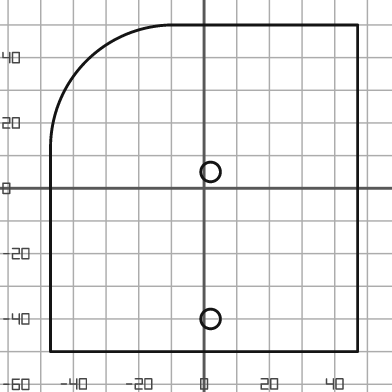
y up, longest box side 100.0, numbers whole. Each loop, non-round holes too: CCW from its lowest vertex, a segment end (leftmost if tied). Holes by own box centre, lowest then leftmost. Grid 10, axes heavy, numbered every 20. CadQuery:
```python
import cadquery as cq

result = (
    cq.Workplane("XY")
    .moveTo(-47.0, -50.0)
    .lineTo(47.0, -50.0)
    .lineTo(47.0, 50.0)
    .lineTo(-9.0, 50.0)
    .threePointArc((-36.0, 39.0), (-47.0, 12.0))
    .close()
    .moveTo(2.0, -40.0)
    .circle(3.0)
    .moveTo(2.0, 5.0)
    .circle(3.0)
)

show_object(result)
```